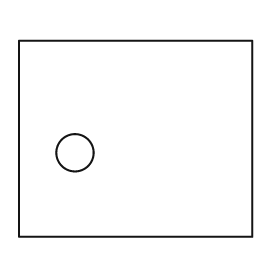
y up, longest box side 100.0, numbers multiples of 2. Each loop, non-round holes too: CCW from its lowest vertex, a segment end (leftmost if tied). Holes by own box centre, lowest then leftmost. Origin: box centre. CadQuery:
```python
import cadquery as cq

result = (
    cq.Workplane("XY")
    .moveTo(-50.0, -42.0)
    .lineTo(50.0, -42.0)
    .lineTo(50.0, 42.0)
    .lineTo(-50.0, 42.0)
    .close()
    .moveTo(-26.0, -6.0)
    .circle(8.0)
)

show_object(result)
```